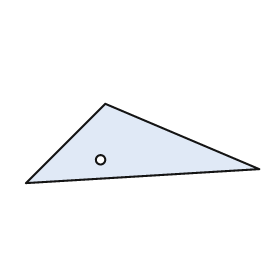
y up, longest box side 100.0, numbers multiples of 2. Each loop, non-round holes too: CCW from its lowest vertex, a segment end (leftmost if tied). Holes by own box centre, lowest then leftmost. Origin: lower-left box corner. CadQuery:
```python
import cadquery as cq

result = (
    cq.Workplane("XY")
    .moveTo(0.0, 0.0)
    .lineTo(100.0, 6.0)
    .lineTo(34.0, 34.0)
    .close()
    .moveTo(32.0, 10.0)
    .circle(2.0)
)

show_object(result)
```